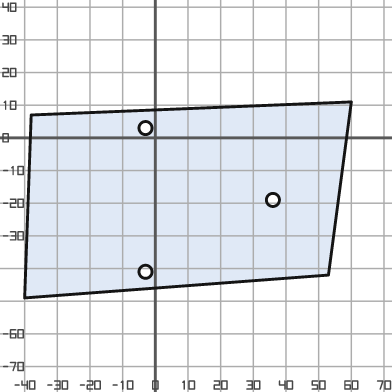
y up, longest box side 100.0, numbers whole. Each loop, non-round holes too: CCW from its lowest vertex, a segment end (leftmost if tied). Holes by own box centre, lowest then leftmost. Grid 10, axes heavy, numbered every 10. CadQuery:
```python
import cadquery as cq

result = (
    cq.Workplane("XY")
    .moveTo(-40.0, -49.0)
    .lineTo(53.0, -42.0)
    .lineTo(60.0, 11.0)
    .lineTo(-38.0, 7.0)
    .close()
    .moveTo(-3.0, -41.0)
    .circle(2.0)
    .moveTo(36.0, -19.0)
    .circle(2.0)
    .moveTo(-3.0, 3.0)
    .circle(2.0)
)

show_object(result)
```